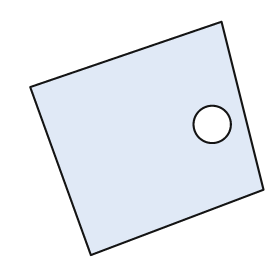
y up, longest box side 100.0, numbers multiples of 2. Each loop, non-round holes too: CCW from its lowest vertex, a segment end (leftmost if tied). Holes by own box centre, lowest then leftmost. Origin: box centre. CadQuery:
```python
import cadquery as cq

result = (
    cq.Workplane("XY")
    .moveTo(-24.0, -50.0)
    .lineTo(50.0, -22.0)
    .lineTo(32.0, 50.0)
    .lineTo(-50.0, 22.0)
    .close()
    .moveTo(28.0, 6.0)
    .circle(8.0)
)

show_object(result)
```